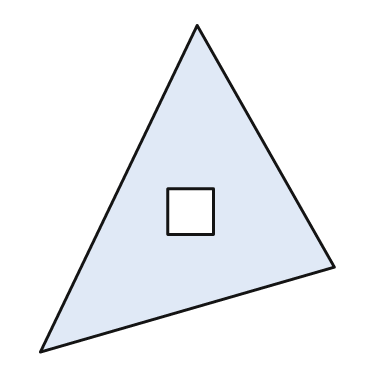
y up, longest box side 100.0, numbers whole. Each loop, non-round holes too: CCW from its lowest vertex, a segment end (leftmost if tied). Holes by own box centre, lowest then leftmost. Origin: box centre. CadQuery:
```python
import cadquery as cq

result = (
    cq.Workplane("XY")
    .moveTo(-45.0, -50.0)
    .lineTo(45.0, -24.0)
    .lineTo(3.0, 50.0)
    .close()
    .moveTo(-6.0, -14.0)
    .lineTo(8.0, -14.0)
    .lineTo(8.0, 0.0)
    .lineTo(-6.0, 0.0)
    .close()
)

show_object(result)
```